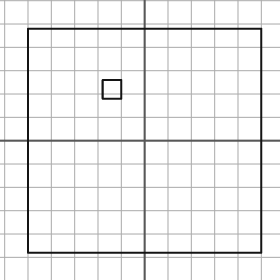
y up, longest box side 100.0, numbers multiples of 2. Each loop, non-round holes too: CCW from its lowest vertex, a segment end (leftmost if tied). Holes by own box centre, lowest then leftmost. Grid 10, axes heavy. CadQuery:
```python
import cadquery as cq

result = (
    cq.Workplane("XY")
    .moveTo(-50.0, -48.0)
    .lineTo(50.0, -48.0)
    .lineTo(50.0, 48.0)
    .lineTo(-50.0, 48.0)
    .close()
    .moveTo(-18.0, 18.0)
    .lineTo(-10.0, 18.0)
    .lineTo(-10.0, 26.0)
    .lineTo(-18.0, 26.0)
    .close()
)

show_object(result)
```